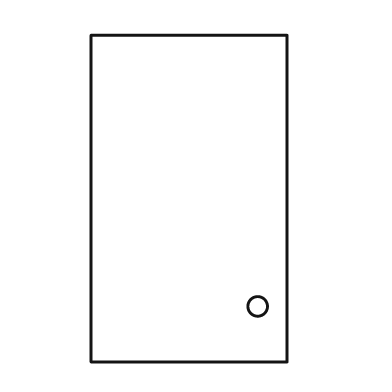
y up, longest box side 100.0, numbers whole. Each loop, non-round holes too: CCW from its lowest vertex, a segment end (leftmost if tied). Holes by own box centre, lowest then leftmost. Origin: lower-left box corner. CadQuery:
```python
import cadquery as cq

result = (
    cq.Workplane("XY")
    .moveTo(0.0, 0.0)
    .lineTo(60.0, 0.0)
    .lineTo(60.0, 100.0)
    .lineTo(0.0, 100.0)
    .close()
    .moveTo(51.0, 17.0)
    .circle(3.0)
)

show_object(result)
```